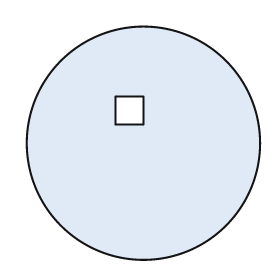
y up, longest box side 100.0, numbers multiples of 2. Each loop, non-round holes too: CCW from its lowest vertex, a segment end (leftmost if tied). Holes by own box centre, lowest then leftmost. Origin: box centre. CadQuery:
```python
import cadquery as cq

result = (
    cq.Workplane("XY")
    .moveTo(0.0, 0.0)
    .circle(50.0)
    .moveTo(-12.0, 8.0)
    .lineTo(0.0, 8.0)
    .lineTo(0.0, 20.0)
    .lineTo(-12.0, 20.0)
    .close()
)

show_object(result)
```